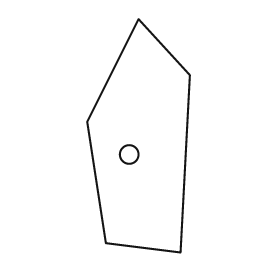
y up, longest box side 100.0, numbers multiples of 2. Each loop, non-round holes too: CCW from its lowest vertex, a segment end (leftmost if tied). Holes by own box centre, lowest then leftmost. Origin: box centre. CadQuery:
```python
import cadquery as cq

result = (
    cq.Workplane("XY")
    .moveTo(18.0, -50.0)
    .lineTo(22.0, 26.0)
    .lineTo(0.0, 50.0)
    .lineTo(-22.0, 6.0)
    .lineTo(-14.0, -46.0)
    .close()
    .moveTo(-4.0, -8.0)
    .circle(4.0)
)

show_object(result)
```